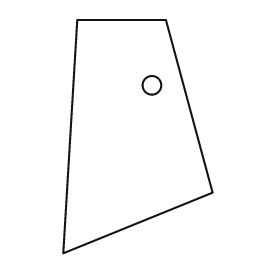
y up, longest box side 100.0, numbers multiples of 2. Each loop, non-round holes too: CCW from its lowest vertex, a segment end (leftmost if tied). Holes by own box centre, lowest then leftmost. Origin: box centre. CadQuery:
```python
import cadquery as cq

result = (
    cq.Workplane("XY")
    .moveTo(-32.0, -50.0)
    .lineTo(32.0, -24.0)
    .lineTo(12.0, 50.0)
    .lineTo(-26.0, 50.0)
    .close()
    .moveTo(6.0, 22.0)
    .circle(4.0)
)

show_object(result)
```